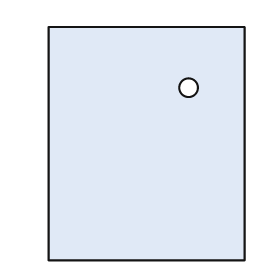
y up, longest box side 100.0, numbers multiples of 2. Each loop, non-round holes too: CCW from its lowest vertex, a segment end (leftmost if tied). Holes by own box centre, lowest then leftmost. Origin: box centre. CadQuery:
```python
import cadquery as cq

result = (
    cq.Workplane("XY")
    .moveTo(-42.0, -50.0)
    .lineTo(42.0, -50.0)
    .lineTo(42.0, 50.0)
    .lineTo(-42.0, 50.0)
    .close()
    .moveTo(18.0, 24.0)
    .circle(4.0)
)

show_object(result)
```